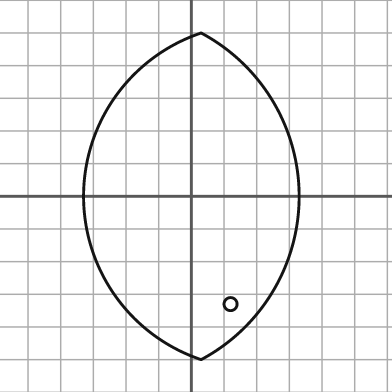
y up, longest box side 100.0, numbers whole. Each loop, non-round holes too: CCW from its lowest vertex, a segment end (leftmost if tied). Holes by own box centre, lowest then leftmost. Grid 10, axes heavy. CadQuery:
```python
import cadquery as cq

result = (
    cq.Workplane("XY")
    .moveTo(3.0, -50.0)
    .threePointArc((33.0, 0.0), (3.0, 50.0))
    .threePointArc((-33.0, 0.0), (3.0, -50.0))
    .close()
    .moveTo(12.0, -33.0)
    .circle(2.0)
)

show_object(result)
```